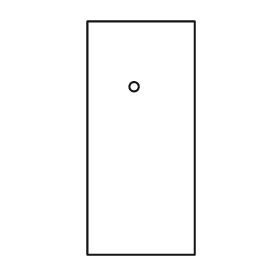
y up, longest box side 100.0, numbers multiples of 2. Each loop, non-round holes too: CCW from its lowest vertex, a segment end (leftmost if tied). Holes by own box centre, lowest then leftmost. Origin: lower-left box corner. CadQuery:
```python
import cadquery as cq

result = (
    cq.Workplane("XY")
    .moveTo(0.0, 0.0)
    .lineTo(46.0, 0.0)
    .lineTo(46.0, 100.0)
    .lineTo(0.0, 100.0)
    .close()
    .moveTo(20.0, 72.0)
    .circle(2.0)
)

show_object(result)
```